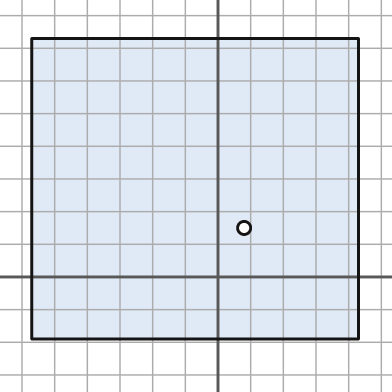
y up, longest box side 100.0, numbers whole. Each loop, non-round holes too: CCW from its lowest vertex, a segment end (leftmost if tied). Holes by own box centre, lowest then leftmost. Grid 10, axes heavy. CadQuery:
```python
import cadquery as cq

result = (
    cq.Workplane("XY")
    .moveTo(-57.0, -19.0)
    .lineTo(43.0, -19.0)
    .lineTo(43.0, 73.0)
    .lineTo(-57.0, 73.0)
    .close()
    .moveTo(8.0, 15.0)
    .circle(2.0)
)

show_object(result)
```